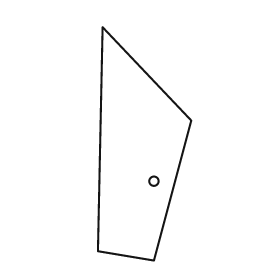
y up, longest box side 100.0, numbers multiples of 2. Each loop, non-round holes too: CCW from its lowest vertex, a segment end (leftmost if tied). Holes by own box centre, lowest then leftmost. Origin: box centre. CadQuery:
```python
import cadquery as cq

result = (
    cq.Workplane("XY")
    .moveTo(4.0, -50.0)
    .lineTo(20.0, 10.0)
    .lineTo(-18.0, 50.0)
    .lineTo(-20.0, -46.0)
    .close()
    .moveTo(4.0, -16.0)
    .circle(2.0)
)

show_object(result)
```